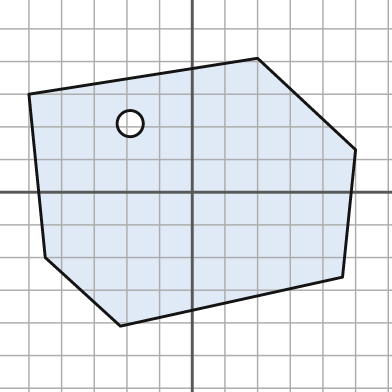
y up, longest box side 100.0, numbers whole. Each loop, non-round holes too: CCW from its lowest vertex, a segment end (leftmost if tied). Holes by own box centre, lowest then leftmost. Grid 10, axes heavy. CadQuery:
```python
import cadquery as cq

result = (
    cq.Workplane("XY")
    .moveTo(-22.0, -41.0)
    .lineTo(46.0, -26.0)
    .lineTo(50.0, 13.0)
    .lineTo(20.0, 41.0)
    .lineTo(-50.0, 30.0)
    .lineTo(-45.0, -20.0)
    .close()
    .moveTo(-19.0, 21.0)
    .circle(4.0)
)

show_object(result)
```